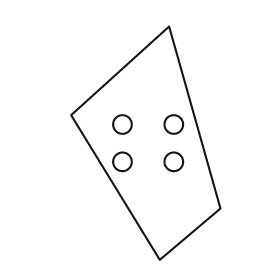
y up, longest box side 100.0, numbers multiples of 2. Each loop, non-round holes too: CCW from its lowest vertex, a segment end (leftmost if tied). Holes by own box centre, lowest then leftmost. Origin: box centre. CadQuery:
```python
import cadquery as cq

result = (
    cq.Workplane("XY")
    .moveTo(6.0, -50.0)
    .lineTo(32.0, -28.0)
    .lineTo(10.0, 50.0)
    .lineTo(-32.0, 12.0)
    .close()
    .moveTo(-10.0, -8.0)
    .circle(4.0)
    .moveTo(12.0, -8.0)
    .circle(4.0)
    .moveTo(-10.0, 8.0)
    .circle(4.0)
    .moveTo(12.0, 8.0)
    .circle(4.0)
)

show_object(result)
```